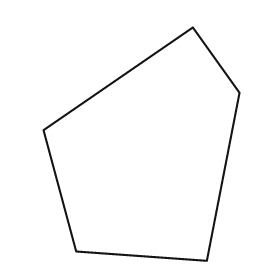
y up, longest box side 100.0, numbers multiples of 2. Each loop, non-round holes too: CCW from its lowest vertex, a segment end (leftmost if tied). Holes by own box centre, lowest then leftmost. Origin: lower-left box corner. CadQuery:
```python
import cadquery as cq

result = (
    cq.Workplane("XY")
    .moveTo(70.0, 0.0)
    .lineTo(84.0, 72.0)
    .lineTo(64.0, 100.0)
    .lineTo(0.0, 56.0)
    .lineTo(14.0, 4.0)
    .close()
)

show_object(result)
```